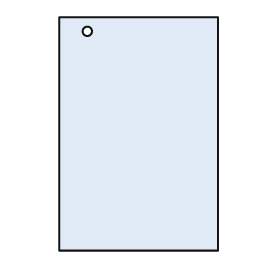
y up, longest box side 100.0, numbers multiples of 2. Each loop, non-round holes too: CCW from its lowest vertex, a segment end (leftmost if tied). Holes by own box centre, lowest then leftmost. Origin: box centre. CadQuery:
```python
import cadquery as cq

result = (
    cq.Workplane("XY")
    .moveTo(-34.0, -50.0)
    .lineTo(34.0, -50.0)
    .lineTo(34.0, 50.0)
    .lineTo(-34.0, 50.0)
    .close()
    .moveTo(-22.0, 44.0)
    .circle(2.0)
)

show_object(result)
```